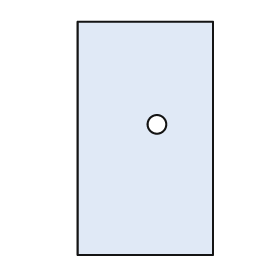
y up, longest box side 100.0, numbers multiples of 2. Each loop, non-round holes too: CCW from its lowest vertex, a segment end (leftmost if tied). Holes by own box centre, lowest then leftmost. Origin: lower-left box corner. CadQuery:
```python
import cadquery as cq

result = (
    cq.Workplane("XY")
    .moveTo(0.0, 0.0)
    .lineTo(58.0, 0.0)
    .lineTo(58.0, 100.0)
    .lineTo(0.0, 100.0)
    .close()
    .moveTo(34.0, 56.0)
    .circle(4.0)
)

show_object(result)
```